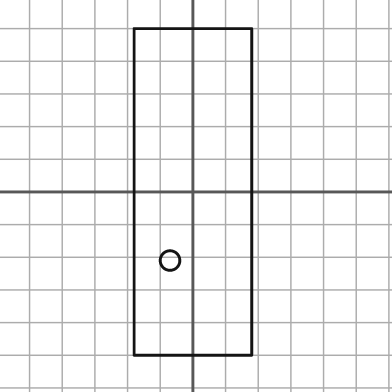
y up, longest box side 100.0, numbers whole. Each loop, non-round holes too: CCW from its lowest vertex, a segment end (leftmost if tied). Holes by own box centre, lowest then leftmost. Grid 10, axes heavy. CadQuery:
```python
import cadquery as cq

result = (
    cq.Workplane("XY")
    .moveTo(-18.0, -50.0)
    .lineTo(18.0, -50.0)
    .lineTo(18.0, 50.0)
    .lineTo(-18.0, 50.0)
    .close()
    .moveTo(-7.0, -21.0)
    .circle(3.0)
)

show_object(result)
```